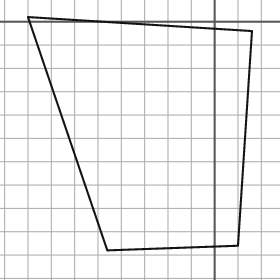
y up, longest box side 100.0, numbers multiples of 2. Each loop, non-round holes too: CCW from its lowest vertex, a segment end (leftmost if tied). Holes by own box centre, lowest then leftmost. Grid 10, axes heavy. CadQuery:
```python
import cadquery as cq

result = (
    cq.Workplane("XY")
    .moveTo(-46.0, -98.0)
    .lineTo(10.0, -96.0)
    .lineTo(16.0, -4.0)
    .lineTo(-80.0, 2.0)
    .close()
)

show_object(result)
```